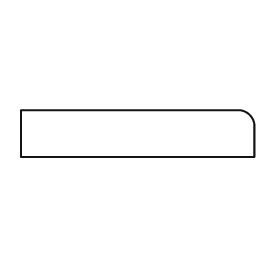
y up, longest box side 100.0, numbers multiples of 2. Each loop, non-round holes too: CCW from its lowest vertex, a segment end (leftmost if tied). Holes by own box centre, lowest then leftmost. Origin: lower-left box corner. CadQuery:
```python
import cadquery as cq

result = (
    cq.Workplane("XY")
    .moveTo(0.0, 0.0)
    .lineTo(100.0, 0.0)
    .lineTo(100.0, 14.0)
    .threePointArc((98.0, 18.0), (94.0, 20.0))
    .lineTo(0.0, 20.0)
    .close()
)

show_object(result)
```